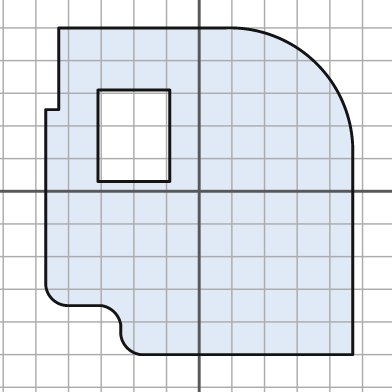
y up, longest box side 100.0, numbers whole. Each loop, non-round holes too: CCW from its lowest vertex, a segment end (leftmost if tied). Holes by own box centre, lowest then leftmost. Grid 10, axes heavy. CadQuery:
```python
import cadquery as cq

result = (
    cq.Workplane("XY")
    .moveTo(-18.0, -50.0)
    .lineTo(47.0, -50.0)
    .lineTo(47.0, 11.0)
    .threePointArc((36.0, 39.0), (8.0, 50.0))
    .lineTo(-43.0, 50.0)
    .lineTo(-43.0, 25.0)
    .lineTo(-47.0, 25.0)
    .lineTo(-47.0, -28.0)
    .threePointArc((-45.0, -33.0), (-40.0, -35.0))
    .lineTo(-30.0, -35.0)
    .threePointArc((-26.0, -37.0), (-24.0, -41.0))
    .lineTo(-24.0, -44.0)
    .threePointArc((-22.0, -48.0), (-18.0, -50.0))
    .close()
    .moveTo(-31.0, 3.0)
    .lineTo(-9.0, 3.0)
    .lineTo(-9.0, 31.0)
    .lineTo(-31.0, 31.0)
    .close()
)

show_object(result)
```